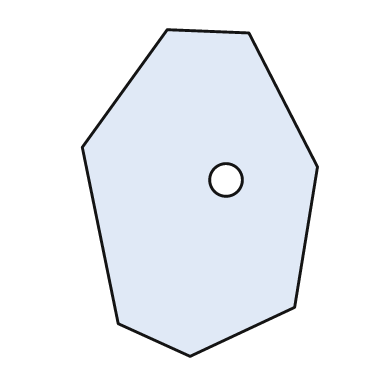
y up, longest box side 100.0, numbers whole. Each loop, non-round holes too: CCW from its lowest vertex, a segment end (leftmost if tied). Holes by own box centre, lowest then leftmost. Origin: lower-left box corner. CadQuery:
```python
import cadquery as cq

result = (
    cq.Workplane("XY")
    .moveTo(33.0, 0.0)
    .lineTo(65.0, 15.0)
    .lineTo(72.0, 58.0)
    .lineTo(51.0, 99.0)
    .lineTo(26.0, 100.0)
    .lineTo(0.0, 64.0)
    .lineTo(11.0, 10.0)
    .close()
    .moveTo(44.0, 54.0)
    .circle(5.0)
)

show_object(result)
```